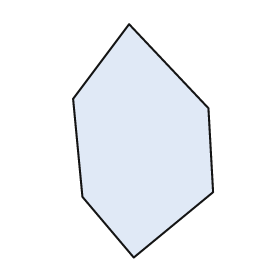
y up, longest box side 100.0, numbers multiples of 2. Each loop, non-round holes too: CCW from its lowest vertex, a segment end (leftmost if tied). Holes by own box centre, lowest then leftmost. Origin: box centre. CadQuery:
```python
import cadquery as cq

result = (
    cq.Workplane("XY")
    .moveTo(-4.0, -50.0)
    .lineTo(30.0, -22.0)
    .lineTo(28.0, 14.0)
    .lineTo(-6.0, 50.0)
    .lineTo(-30.0, 18.0)
    .lineTo(-26.0, -24.0)
    .close()
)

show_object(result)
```